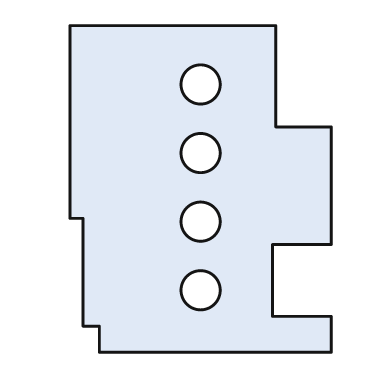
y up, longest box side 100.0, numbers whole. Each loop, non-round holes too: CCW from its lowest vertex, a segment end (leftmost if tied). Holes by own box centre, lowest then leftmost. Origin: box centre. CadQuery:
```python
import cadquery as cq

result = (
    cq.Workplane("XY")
    .moveTo(-31.0, -50.0)
    .lineTo(40.0, -50.0)
    .lineTo(40.0, -39.0)
    .lineTo(22.0, -39.0)
    .lineTo(22.0, -17.0)
    .lineTo(40.0, -17.0)
    .lineTo(40.0, 19.0)
    .lineTo(23.0, 19.0)
    .lineTo(23.0, 50.0)
    .lineTo(-40.0, 50.0)
    .lineTo(-40.0, -9.0)
    .lineTo(-36.0, -9.0)
    .lineTo(-36.0, -42.0)
    .lineTo(-31.0, -42.0)
    .close()
    .moveTo(0.0, -31.0)
    .circle(6.0)
    .moveTo(0.0, -10.0)
    .circle(6.0)
    .moveTo(0.0, 11.0)
    .circle(6.0)
    .moveTo(0.0, 32.0)
    .circle(6.0)
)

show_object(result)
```